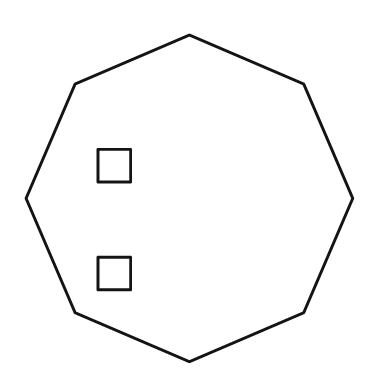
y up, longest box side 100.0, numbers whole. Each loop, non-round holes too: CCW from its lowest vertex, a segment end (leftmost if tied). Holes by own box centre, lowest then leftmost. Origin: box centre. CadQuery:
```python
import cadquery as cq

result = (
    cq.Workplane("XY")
    .moveTo(0.0, -50.0)
    .lineTo(35.0, -35.0)
    .lineTo(50.0, 0.0)
    .lineTo(35.0, 35.0)
    .lineTo(0.0, 50.0)
    .lineTo(-35.0, 35.0)
    .lineTo(-50.0, 0.0)
    .lineTo(-35.0, -35.0)
    .close()
    .moveTo(-28.0, -28.0)
    .lineTo(-18.0, -28.0)
    .lineTo(-18.0, -18.0)
    .lineTo(-28.0, -18.0)
    .close()
    .moveTo(-28.0, 5.0)
    .lineTo(-18.0, 5.0)
    .lineTo(-18.0, 15.0)
    .lineTo(-28.0, 15.0)
    .close()
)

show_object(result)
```